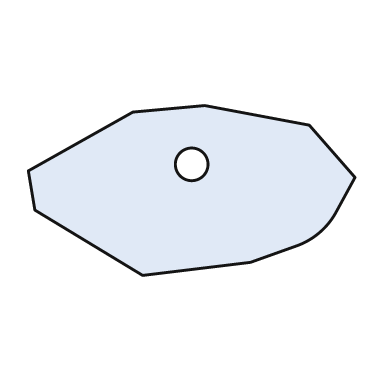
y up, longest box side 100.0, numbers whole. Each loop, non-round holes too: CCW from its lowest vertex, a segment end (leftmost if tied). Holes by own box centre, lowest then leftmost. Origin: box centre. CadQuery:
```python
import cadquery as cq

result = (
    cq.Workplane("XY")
    .moveTo(-15.0, -26.0)
    .lineTo(18.0, -22.0)
    .lineTo(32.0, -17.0)
    .threePointArc((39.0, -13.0), (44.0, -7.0))
    .lineTo(50.0, 4.0)
    .lineTo(36.0, 20.0)
    .lineTo(4.0, 26.0)
    .lineTo(-18.0, 24.0)
    .lineTo(-50.0, 6.0)
    .lineTo(-48.0, -6.0)
    .close()
    .moveTo(0.0, 8.0)
    .circle(5.0)
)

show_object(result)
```